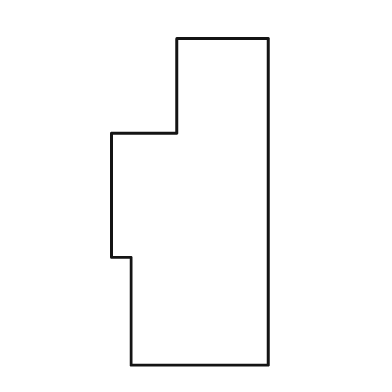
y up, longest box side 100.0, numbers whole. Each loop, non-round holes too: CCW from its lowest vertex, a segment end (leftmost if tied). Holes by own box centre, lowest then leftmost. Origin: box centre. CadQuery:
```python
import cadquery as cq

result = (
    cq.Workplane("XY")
    .moveTo(-18.0, -50.0)
    .lineTo(24.0, -50.0)
    .lineTo(24.0, 50.0)
    .lineTo(-4.0, 50.0)
    .lineTo(-4.0, 21.0)
    .lineTo(-24.0, 21.0)
    .lineTo(-24.0, -17.0)
    .lineTo(-18.0, -17.0)
    .close()
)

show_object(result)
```